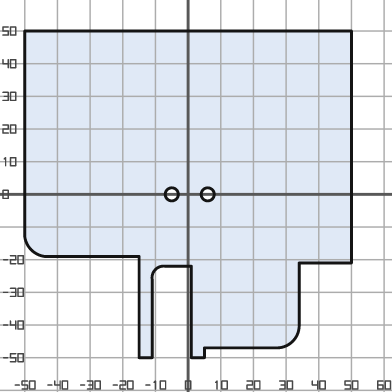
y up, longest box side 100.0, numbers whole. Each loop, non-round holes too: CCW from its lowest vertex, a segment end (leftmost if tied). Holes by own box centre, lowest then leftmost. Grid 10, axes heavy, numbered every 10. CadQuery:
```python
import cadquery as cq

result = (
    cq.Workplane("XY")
    .moveTo(-15.0, -50.0)
    .lineTo(-11.0, -50.0)
    .lineTo(-11.0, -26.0)
    .threePointArc((-10.0, -23.0), (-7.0, -22.0))
    .lineTo(1.0, -22.0)
    .lineTo(1.0, -50.0)
    .lineTo(5.0, -50.0)
    .lineTo(5.0, -47.0)
    .lineTo(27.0, -47.0)
    .threePointArc((32.0, -45.0), (34.0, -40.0))
    .lineTo(34.0, -21.0)
    .lineTo(50.0, -21.0)
    .lineTo(50.0, 50.0)
    .lineTo(-50.0, 50.0)
    .lineTo(-50.0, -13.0)
    .threePointArc((-48.0, -17.0), (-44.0, -19.0))
    .lineTo(-15.0, -19.0)
    .close()
    .moveTo(-5.0, 0.0)
    .circle(2.0)
    .moveTo(6.0, 0.0)
    .circle(2.0)
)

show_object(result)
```